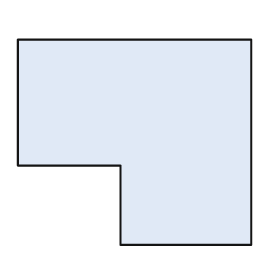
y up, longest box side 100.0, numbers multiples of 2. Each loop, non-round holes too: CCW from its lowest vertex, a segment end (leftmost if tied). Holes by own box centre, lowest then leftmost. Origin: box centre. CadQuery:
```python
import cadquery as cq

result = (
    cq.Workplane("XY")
    .moveTo(-6.0, -44.0)
    .lineTo(50.0, -44.0)
    .lineTo(50.0, 44.0)
    .lineTo(-50.0, 44.0)
    .lineTo(-50.0, -10.0)
    .lineTo(-6.0, -10.0)
    .close()
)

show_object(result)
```